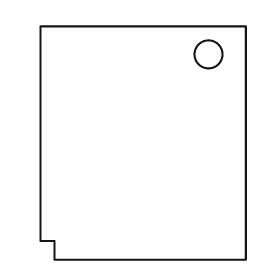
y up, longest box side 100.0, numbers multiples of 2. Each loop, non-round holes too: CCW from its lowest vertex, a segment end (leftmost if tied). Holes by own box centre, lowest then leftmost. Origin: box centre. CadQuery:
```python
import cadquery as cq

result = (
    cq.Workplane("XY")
    .moveTo(-38.0, -50.0)
    .lineTo(44.0, -50.0)
    .lineTo(44.0, 50.0)
    .lineTo(-44.0, 50.0)
    .lineTo(-44.0, -42.0)
    .lineTo(-38.0, -42.0)
    .close()
    .moveTo(28.0, 38.0)
    .circle(6.0)
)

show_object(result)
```